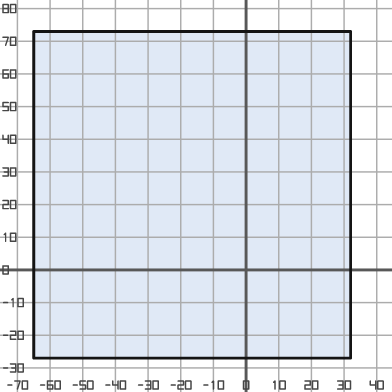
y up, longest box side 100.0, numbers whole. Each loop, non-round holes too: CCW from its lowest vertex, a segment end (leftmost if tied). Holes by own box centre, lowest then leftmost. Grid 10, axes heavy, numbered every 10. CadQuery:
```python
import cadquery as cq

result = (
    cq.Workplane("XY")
    .moveTo(-65.0, -27.0)
    .lineTo(32.0, -27.0)
    .lineTo(32.0, 73.0)
    .lineTo(-65.0, 73.0)
    .close()
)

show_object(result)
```